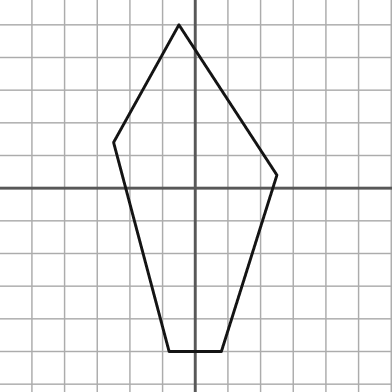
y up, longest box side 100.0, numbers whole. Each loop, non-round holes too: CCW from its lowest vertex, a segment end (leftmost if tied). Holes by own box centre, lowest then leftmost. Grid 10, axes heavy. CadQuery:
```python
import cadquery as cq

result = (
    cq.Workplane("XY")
    .moveTo(-8.0, -50.0)
    .lineTo(8.0, -50.0)
    .lineTo(25.0, 4.0)
    .lineTo(-5.0, 50.0)
    .lineTo(-25.0, 14.0)
    .close()
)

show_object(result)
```